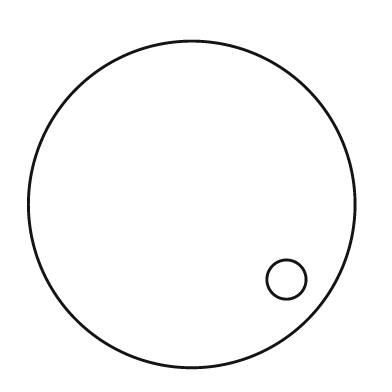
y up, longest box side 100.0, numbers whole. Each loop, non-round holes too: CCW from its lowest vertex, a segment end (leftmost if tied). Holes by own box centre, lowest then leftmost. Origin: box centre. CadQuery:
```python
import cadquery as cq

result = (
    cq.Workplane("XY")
    .moveTo(0.0, 0.0)
    .circle(50.0)
    .moveTo(29.0, -23.0)
    .circle(6.0)
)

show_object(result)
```